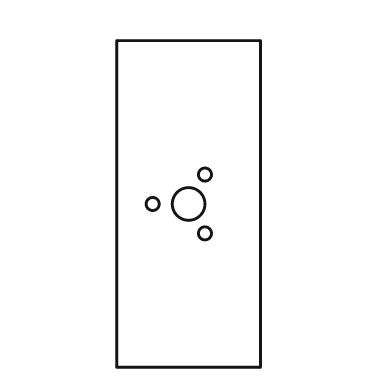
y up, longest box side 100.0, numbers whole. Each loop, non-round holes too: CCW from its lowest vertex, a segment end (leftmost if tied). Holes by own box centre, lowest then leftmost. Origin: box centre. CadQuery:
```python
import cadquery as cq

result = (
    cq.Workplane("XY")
    .moveTo(-22.0, -50.0)
    .lineTo(22.0, -50.0)
    .lineTo(22.0, 50.0)
    .lineTo(-22.0, 50.0)
    .close()
    .moveTo(5.0, -9.0)
    .circle(2.0)
    .moveTo(-11.0, 0.0)
    .circle(2.0)
    .moveTo(0.0, 0.0)
    .circle(5.0)
    .moveTo(5.0, 9.0)
    .circle(2.0)
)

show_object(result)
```